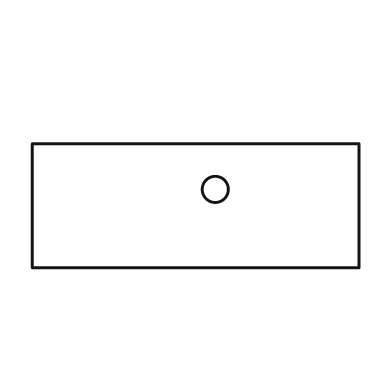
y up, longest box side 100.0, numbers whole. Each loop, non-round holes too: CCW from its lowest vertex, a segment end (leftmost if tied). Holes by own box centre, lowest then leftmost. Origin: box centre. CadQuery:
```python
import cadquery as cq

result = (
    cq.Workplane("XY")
    .moveTo(-50.0, -19.0)
    .lineTo(50.0, -19.0)
    .lineTo(50.0, 19.0)
    .lineTo(-50.0, 19.0)
    .close()
    .moveTo(6.0, 5.0)
    .circle(4.0)
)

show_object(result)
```